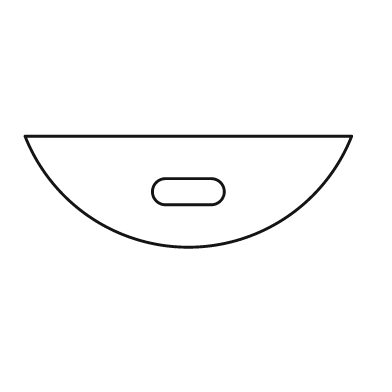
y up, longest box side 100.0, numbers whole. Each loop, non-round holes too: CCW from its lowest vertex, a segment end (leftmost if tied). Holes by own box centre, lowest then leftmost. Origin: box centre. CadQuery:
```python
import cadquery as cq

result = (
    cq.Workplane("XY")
    .moveTo(-50.0, 17.0)
    .threePointArc((0.0, -17.0), (50.0, 17.0))
    .close()
    .moveTo(-7.0, -4.0)
    .lineTo(7.0, -4.0)
    .threePointArc((11.0, 0.0), (7.0, 4.0))
    .lineTo(-7.0, 4.0)
    .threePointArc((-11.0, 0.0), (-7.0, -4.0))
    .close()
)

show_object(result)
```